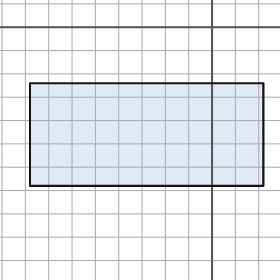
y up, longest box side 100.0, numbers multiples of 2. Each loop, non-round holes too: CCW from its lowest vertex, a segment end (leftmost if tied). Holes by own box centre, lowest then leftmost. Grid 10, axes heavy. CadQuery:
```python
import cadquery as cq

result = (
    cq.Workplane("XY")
    .moveTo(-78.0, -68.0)
    .lineTo(22.0, -68.0)
    .lineTo(22.0, -24.0)
    .lineTo(-78.0, -24.0)
    .close()
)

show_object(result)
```